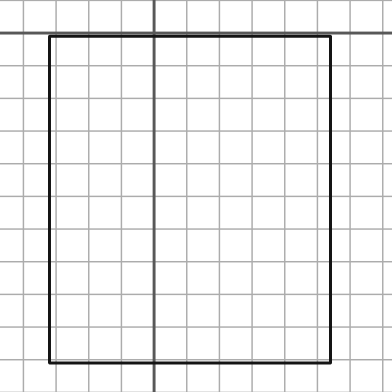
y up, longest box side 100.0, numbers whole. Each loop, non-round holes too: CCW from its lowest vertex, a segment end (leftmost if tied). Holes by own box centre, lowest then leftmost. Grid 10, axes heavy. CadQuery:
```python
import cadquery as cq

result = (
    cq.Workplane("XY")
    .moveTo(-32.0, -101.0)
    .lineTo(54.0, -101.0)
    .lineTo(54.0, -1.0)
    .lineTo(-32.0, -1.0)
    .close()
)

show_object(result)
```